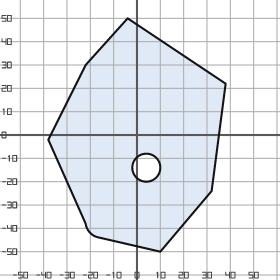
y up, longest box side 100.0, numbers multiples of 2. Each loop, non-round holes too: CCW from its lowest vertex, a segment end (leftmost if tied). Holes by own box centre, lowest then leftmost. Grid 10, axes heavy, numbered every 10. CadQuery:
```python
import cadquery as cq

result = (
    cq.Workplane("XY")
    .moveTo(10.0, -50.0)
    .lineTo(32.0, -24.0)
    .lineTo(38.0, 22.0)
    .lineTo(-4.0, 50.0)
    .lineTo(-22.0, 30.0)
    .lineTo(-38.0, -2.0)
    .lineTo(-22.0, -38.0)
    .threePointArc((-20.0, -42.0), (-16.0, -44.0))
    .close()
    .moveTo(4.0, -14.0)
    .circle(6.0)
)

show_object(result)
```